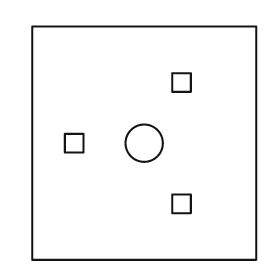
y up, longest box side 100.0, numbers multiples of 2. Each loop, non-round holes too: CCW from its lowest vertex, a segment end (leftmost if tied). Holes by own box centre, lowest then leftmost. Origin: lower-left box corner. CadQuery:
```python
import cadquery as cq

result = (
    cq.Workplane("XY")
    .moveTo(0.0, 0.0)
    .lineTo(96.0, 0.0)
    .lineTo(96.0, 100.0)
    .lineTo(0.0, 100.0)
    .close()
    .moveTo(60.0, 20.0)
    .lineTo(68.0, 20.0)
    .lineTo(68.0, 28.0)
    .lineTo(60.0, 28.0)
    .close()
    .moveTo(14.0, 46.0)
    .lineTo(22.0, 46.0)
    .lineTo(22.0, 54.0)
    .lineTo(14.0, 54.0)
    .close()
    .moveTo(48.0, 50.0)
    .circle(8.0)
    .moveTo(60.0, 72.0)
    .lineTo(68.0, 72.0)
    .lineTo(68.0, 80.0)
    .lineTo(60.0, 80.0)
    .close()
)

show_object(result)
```